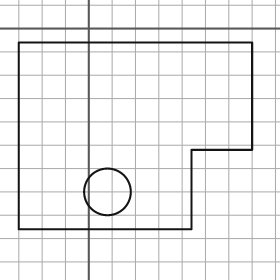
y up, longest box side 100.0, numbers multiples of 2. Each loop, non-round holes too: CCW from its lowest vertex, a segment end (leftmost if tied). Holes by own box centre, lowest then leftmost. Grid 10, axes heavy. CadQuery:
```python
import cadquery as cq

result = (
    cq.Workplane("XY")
    .moveTo(-30.0, -86.0)
    .lineTo(44.0, -86.0)
    .lineTo(44.0, -52.0)
    .lineTo(70.0, -52.0)
    .lineTo(70.0, -6.0)
    .lineTo(-30.0, -6.0)
    .close()
    .moveTo(8.0, -70.0)
    .circle(10.0)
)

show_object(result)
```